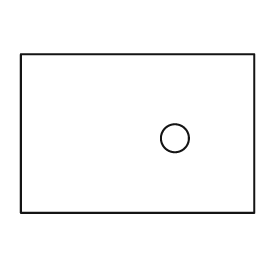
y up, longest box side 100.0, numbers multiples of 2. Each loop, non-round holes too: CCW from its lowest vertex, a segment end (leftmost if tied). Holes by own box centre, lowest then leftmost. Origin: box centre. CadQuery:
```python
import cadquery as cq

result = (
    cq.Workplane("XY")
    .moveTo(-50.0, -34.0)
    .lineTo(50.0, -34.0)
    .lineTo(50.0, 34.0)
    .lineTo(-50.0, 34.0)
    .close()
    .moveTo(16.0, -2.0)
    .circle(6.0)
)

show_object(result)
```